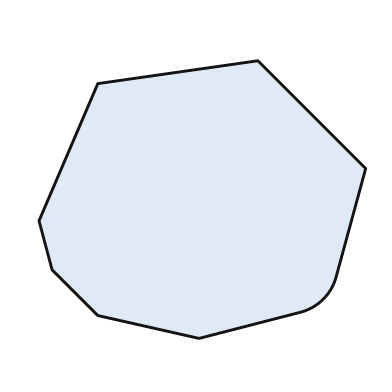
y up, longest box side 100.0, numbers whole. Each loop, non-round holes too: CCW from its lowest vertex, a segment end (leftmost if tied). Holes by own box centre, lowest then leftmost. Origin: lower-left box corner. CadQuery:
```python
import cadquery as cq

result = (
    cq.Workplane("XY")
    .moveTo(49.0, 0.0)
    .lineTo(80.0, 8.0)
    .threePointArc((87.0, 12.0), (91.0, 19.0))
    .lineTo(100.0, 52.0)
    .lineTo(67.0, 85.0)
    .lineTo(18.0, 78.0)
    .lineTo(0.0, 36.0)
    .lineTo(4.0, 21.0)
    .lineTo(18.0, 7.0)
    .close()
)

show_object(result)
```